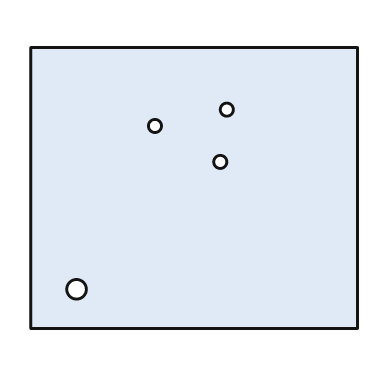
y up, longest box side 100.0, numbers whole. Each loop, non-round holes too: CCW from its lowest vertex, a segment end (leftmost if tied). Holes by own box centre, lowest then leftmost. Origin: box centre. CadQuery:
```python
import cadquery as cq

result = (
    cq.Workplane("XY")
    .moveTo(-50.0, -43.0)
    .lineTo(50.0, -43.0)
    .lineTo(50.0, 43.0)
    .lineTo(-50.0, 43.0)
    .close()
    .moveTo(-36.0, -31.0)
    .circle(3.0)
    .moveTo(8.0, 8.0)
    .circle(2.0)
    .moveTo(-12.0, 19.0)
    .circle(2.0)
    .moveTo(10.0, 24.0)
    .circle(2.0)
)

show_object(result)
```